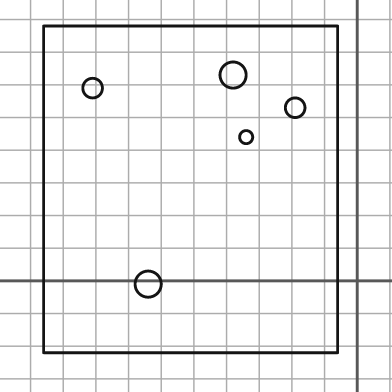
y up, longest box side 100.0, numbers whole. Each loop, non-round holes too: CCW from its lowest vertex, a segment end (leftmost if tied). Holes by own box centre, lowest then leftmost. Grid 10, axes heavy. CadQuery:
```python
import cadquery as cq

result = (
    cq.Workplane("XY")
    .moveTo(-96.0, -22.0)
    .lineTo(-6.0, -22.0)
    .lineTo(-6.0, 78.0)
    .lineTo(-96.0, 78.0)
    .close()
    .moveTo(-64.0, -1.0)
    .circle(4.0)
    .moveTo(-34.0, 44.0)
    .circle(2.0)
    .moveTo(-19.0, 53.0)
    .circle(3.0)
    .moveTo(-81.0, 59.0)
    .circle(3.0)
    .moveTo(-38.0, 63.0)
    .circle(4.0)
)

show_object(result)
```